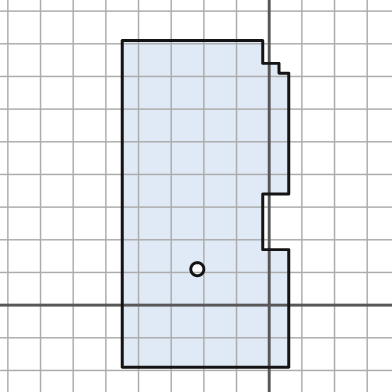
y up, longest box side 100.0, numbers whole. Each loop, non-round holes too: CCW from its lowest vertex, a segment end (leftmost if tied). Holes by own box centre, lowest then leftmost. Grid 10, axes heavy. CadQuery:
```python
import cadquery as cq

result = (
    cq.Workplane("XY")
    .moveTo(-45.0, -19.0)
    .lineTo(6.0, -19.0)
    .lineTo(6.0, 17.0)
    .lineTo(-2.0, 17.0)
    .lineTo(-2.0, 34.0)
    .lineTo(6.0, 34.0)
    .lineTo(6.0, 71.0)
    .lineTo(3.0, 71.0)
    .lineTo(3.0, 74.0)
    .lineTo(-2.0, 74.0)
    .lineTo(-2.0, 81.0)
    .lineTo(-45.0, 81.0)
    .close()
    .moveTo(-22.0, 11.0)
    .circle(2.0)
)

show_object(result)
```